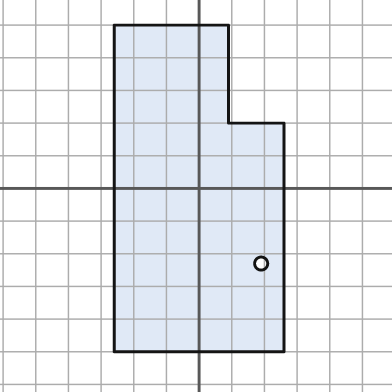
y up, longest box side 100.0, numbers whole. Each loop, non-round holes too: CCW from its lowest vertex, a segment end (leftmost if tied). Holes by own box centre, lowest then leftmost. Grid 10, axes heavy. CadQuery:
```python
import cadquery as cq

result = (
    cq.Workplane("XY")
    .moveTo(-26.0, -50.0)
    .lineTo(26.0, -50.0)
    .lineTo(26.0, 20.0)
    .lineTo(9.0, 20.0)
    .lineTo(9.0, 50.0)
    .lineTo(-26.0, 50.0)
    .close()
    .moveTo(19.0, -23.0)
    .circle(2.0)
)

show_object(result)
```